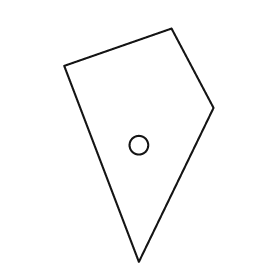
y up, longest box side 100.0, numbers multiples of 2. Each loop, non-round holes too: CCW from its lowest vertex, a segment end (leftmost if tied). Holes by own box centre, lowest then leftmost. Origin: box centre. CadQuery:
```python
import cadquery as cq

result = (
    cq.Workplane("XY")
    .moveTo(0.0, -50.0)
    .lineTo(32.0, 16.0)
    .lineTo(14.0, 50.0)
    .lineTo(-32.0, 34.0)
    .close()
    .moveTo(0.0, 0.0)
    .circle(4.0)
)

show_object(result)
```